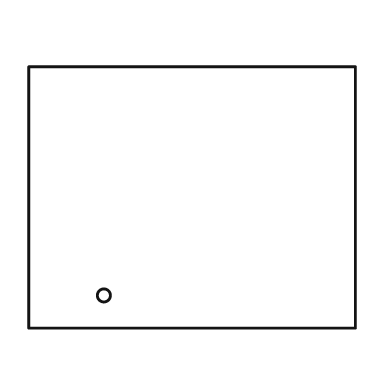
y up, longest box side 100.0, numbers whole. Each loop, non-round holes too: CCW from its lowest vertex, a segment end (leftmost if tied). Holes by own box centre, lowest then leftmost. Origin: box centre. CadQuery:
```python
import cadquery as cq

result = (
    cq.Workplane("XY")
    .moveTo(-50.0, -40.0)
    .lineTo(50.0, -40.0)
    .lineTo(50.0, 40.0)
    .lineTo(-50.0, 40.0)
    .close()
    .moveTo(-27.0, -30.0)
    .circle(2.0)
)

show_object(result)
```